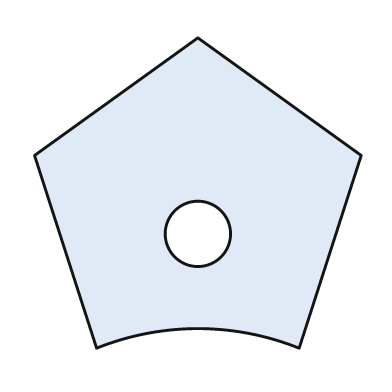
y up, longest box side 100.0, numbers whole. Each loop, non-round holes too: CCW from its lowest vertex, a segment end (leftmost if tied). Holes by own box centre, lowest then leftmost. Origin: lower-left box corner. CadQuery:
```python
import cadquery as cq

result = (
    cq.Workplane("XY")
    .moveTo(19.0, 0.0)
    .threePointArc((50.0, 6.0), (81.0, 0.0))
    .lineTo(100.0, 59.0)
    .lineTo(50.0, 95.0)
    .lineTo(0.0, 59.0)
    .close()
    .moveTo(50.0, 35.0)
    .circle(10.0)
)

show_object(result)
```